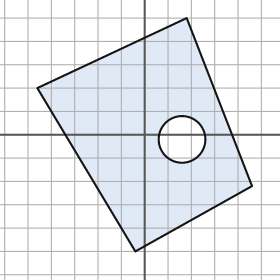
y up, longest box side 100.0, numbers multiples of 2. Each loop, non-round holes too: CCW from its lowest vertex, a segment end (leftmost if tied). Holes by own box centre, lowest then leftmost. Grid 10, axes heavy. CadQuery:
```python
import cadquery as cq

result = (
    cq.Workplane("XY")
    .moveTo(-4.0, -50.0)
    .lineTo(46.0, -22.0)
    .lineTo(18.0, 50.0)
    .lineTo(-46.0, 20.0)
    .close()
    .moveTo(16.0, -2.0)
    .circle(10.0)
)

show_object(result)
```